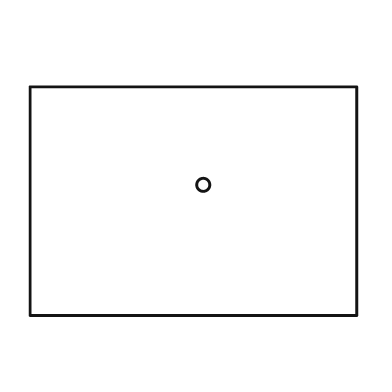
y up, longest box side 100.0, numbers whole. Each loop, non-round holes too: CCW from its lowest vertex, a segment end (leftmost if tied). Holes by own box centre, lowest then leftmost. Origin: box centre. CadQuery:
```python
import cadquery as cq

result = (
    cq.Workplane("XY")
    .moveTo(-50.0, -35.0)
    .lineTo(50.0, -35.0)
    .lineTo(50.0, 35.0)
    .lineTo(-50.0, 35.0)
    .close()
    .moveTo(3.0, 5.0)
    .circle(2.0)
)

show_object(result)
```